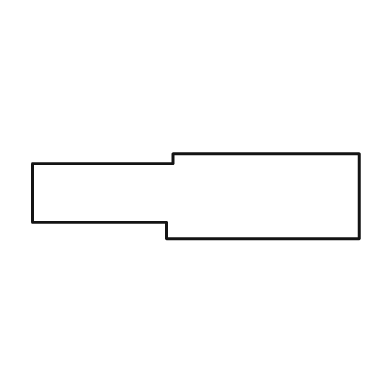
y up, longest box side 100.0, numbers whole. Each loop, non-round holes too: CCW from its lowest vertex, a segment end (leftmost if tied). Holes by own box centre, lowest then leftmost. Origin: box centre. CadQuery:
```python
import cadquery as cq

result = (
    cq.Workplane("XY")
    .moveTo(-9.0, -13.0)
    .lineTo(50.0, -13.0)
    .lineTo(50.0, 13.0)
    .lineTo(-7.0, 13.0)
    .lineTo(-7.0, 10.0)
    .lineTo(-50.0, 10.0)
    .lineTo(-50.0, -8.0)
    .lineTo(-9.0, -8.0)
    .close()
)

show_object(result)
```